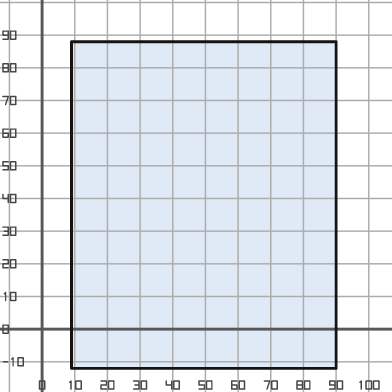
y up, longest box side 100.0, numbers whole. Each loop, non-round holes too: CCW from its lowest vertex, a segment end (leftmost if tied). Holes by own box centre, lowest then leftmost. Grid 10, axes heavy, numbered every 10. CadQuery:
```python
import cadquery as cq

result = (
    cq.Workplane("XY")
    .moveTo(9.0, -12.0)
    .lineTo(90.0, -12.0)
    .lineTo(90.0, 88.0)
    .lineTo(9.0, 88.0)
    .close()
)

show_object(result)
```